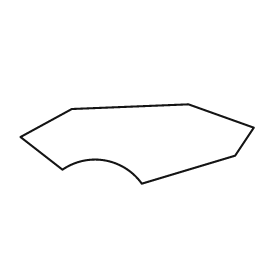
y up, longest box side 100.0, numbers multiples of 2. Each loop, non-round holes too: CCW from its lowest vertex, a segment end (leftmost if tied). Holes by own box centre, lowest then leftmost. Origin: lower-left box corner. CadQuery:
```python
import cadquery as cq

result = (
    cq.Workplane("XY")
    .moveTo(52.0, 0.0)
    .lineTo(92.0, 12.0)
    .lineTo(100.0, 24.0)
    .lineTo(72.0, 34.0)
    .lineTo(22.0, 32.0)
    .lineTo(0.0, 20.0)
    .lineTo(18.0, 6.0)
    .threePointArc((36.0, 10.0), (52.0, 0.0))
    .close()
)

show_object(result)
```